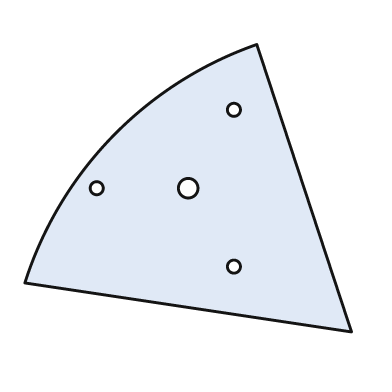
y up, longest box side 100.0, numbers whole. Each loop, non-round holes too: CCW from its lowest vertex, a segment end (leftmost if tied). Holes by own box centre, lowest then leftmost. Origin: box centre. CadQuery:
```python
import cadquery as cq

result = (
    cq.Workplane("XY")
    .moveTo(50.0, -44.0)
    .lineTo(21.0, 44.0)
    .threePointArc((-23.0, 16.0), (-50.0, -29.0))
    .close()
    .moveTo(14.0, -24.0)
    .circle(2.0)
    .moveTo(-28.0, 0.0)
    .circle(2.0)
    .moveTo(0.0, 0.0)
    .circle(3.0)
    .moveTo(14.0, 24.0)
    .circle(2.0)
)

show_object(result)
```